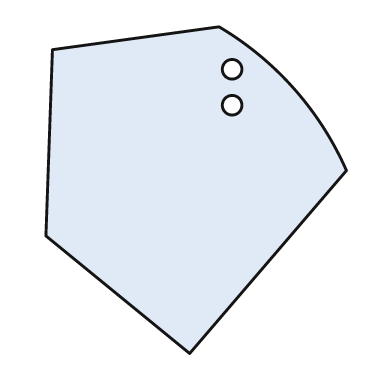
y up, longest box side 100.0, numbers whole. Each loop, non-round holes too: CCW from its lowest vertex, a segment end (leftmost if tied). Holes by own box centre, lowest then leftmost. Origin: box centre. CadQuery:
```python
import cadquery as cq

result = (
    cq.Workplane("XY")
    .moveTo(-2.0, -50.0)
    .lineTo(46.0, 6.0)
    .threePointArc((30.0, 31.0), (7.0, 50.0))
    .lineTo(-44.0, 43.0)
    .lineTo(-46.0, -14.0)
    .close()
    .moveTo(11.0, 26.0)
    .circle(3.0)
    .moveTo(11.0, 37.0)
    .circle(3.0)
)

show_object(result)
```